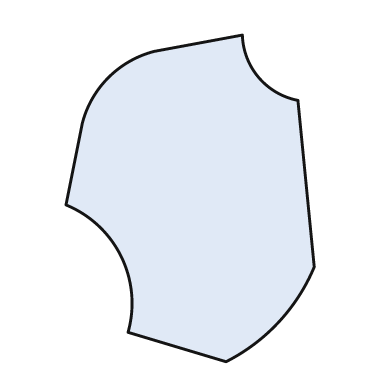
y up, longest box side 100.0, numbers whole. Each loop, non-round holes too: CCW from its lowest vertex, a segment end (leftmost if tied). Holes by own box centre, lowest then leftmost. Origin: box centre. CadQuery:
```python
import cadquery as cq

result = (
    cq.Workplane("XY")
    .moveTo(11.0, -50.0)
    .threePointArc((27.0, -38.0), (38.0, -21.0))
    .lineTo(33.0, 30.0)
    .threePointArc((21.0, 37.0), (16.0, 50.0))
    .lineTo(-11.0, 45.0)
    .threePointArc((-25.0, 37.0), (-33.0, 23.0))
    .lineTo(-38.0, -2.0)
    .threePointArc((-21.0, -18.0), (-19.0, -41.0))
    .close()
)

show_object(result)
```